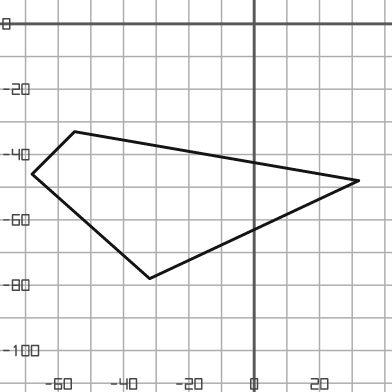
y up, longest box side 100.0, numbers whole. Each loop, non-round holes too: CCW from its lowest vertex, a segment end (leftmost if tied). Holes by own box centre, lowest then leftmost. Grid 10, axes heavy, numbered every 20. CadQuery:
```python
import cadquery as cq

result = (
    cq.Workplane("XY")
    .moveTo(-32.0, -78.0)
    .lineTo(32.0, -48.0)
    .lineTo(-55.0, -33.0)
    .lineTo(-68.0, -46.0)
    .close()
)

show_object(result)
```